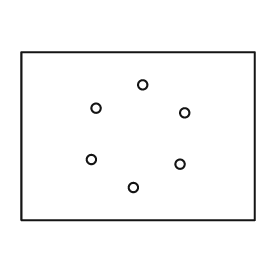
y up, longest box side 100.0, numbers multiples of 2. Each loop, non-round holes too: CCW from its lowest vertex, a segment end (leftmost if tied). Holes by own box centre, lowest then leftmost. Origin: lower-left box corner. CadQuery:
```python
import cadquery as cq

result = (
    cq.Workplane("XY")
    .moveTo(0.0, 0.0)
    .lineTo(100.0, 0.0)
    .lineTo(100.0, 72.0)
    .lineTo(0.0, 72.0)
    .close()
    .moveTo(48.0, 14.0)
    .circle(2.0)
    .moveTo(68.0, 24.0)
    .circle(2.0)
    .moveTo(30.0, 26.0)
    .circle(2.0)
    .moveTo(70.0, 46.0)
    .circle(2.0)
    .moveTo(32.0, 48.0)
    .circle(2.0)
    .moveTo(52.0, 58.0)
    .circle(2.0)
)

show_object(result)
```